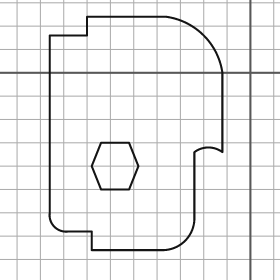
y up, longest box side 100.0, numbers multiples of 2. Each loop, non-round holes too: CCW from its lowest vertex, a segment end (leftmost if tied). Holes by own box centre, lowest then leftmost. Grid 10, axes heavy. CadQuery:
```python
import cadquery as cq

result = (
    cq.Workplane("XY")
    .moveTo(-68.0, -76.0)
    .lineTo(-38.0, -76.0)
    .threePointArc((-28.0, -72.0), (-24.0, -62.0))
    .lineTo(-24.0, -34.0)
    .threePointArc((-18.0, -32.0), (-12.0, -34.0))
    .lineTo(-12.0, 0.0)
    .threePointArc((-20.0, 16.0), (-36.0, 24.0))
    .lineTo(-70.0, 24.0)
    .lineTo(-70.0, 16.0)
    .lineTo(-86.0, 16.0)
    .lineTo(-86.0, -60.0)
    .threePointArc((-84.0, -66.0), (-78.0, -68.0))
    .lineTo(-68.0, -68.0)
    .close()
    .moveTo(-64.0, -50.0)
    .lineTo(-52.0, -50.0)
    .lineTo(-48.0, -40.0)
    .lineTo(-52.0, -30.0)
    .lineTo(-64.0, -30.0)
    .lineTo(-68.0, -40.0)
    .close()
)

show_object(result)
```